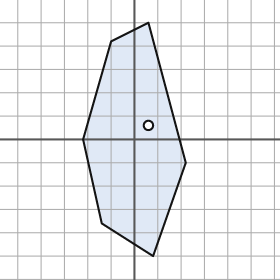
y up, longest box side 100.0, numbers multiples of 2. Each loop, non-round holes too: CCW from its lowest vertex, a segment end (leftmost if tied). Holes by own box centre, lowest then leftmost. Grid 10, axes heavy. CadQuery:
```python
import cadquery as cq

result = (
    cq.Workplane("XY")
    .moveTo(8.0, -50.0)
    .lineTo(22.0, -10.0)
    .lineTo(6.0, 50.0)
    .lineTo(-10.0, 42.0)
    .lineTo(-22.0, 0.0)
    .lineTo(-14.0, -36.0)
    .close()
    .moveTo(6.0, 6.0)
    .circle(2.0)
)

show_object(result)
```